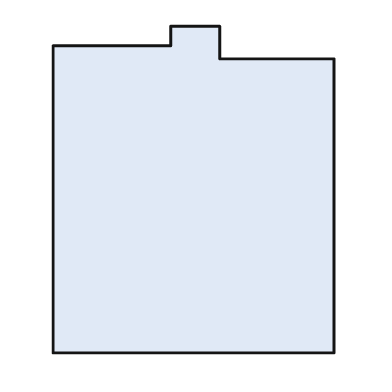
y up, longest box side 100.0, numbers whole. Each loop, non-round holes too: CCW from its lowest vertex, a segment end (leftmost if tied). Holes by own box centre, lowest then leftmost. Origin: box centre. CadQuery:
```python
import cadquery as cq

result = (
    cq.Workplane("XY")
    .moveTo(-43.0, -50.0)
    .lineTo(43.0, -50.0)
    .lineTo(43.0, 40.0)
    .lineTo(8.0, 40.0)
    .lineTo(8.0, 50.0)
    .lineTo(-7.0, 50.0)
    .lineTo(-7.0, 44.0)
    .lineTo(-43.0, 44.0)
    .close()
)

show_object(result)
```